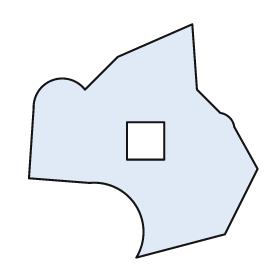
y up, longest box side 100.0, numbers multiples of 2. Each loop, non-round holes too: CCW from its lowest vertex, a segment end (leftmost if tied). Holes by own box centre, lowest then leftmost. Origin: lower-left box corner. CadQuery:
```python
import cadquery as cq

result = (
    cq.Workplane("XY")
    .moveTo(46.0, 0.0)
    .lineTo(84.0, 10.0)
    .lineTo(98.0, 38.0)
    .lineTo(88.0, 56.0)
    .threePointArc((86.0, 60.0), (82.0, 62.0))
    .lineTo(72.0, 72.0)
    .lineTo(70.0, 100.0)
    .lineTo(38.0, 86.0)
    .lineTo(24.0, 72.0)
    .threePointArc((10.0, 76.0), (2.0, 64.0))
    .lineTo(0.0, 34.0)
    .lineTo(26.0, 32.0)
    .threePointArc((46.0, 22.0), (46.0, 0.0))
    .close()
    .moveTo(42.0, 42.0)
    .lineTo(58.0, 42.0)
    .lineTo(58.0, 58.0)
    .lineTo(42.0, 58.0)
    .close()
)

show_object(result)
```